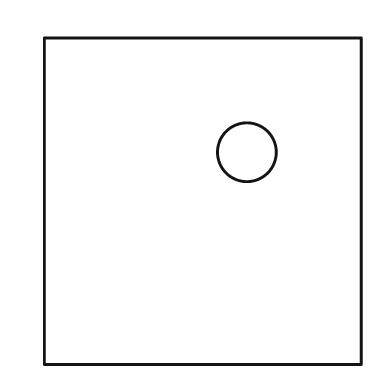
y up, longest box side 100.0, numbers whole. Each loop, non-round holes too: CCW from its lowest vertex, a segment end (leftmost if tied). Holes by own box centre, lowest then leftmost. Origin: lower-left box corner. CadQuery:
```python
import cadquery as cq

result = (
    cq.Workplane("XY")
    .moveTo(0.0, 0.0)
    .lineTo(97.0, 0.0)
    .lineTo(97.0, 100.0)
    .lineTo(0.0, 100.0)
    .close()
    .moveTo(62.0, 65.0)
    .circle(9.0)
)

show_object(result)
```